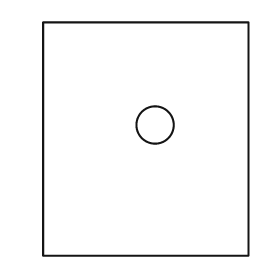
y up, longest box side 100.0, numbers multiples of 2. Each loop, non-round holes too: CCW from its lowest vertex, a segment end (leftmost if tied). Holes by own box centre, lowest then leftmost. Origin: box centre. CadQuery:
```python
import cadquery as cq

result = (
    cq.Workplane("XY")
    .moveTo(-44.0, -50.0)
    .lineTo(44.0, -50.0)
    .lineTo(44.0, 50.0)
    .lineTo(-44.0, 50.0)
    .close()
    .moveTo(4.0, 6.0)
    .circle(8.0)
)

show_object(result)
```